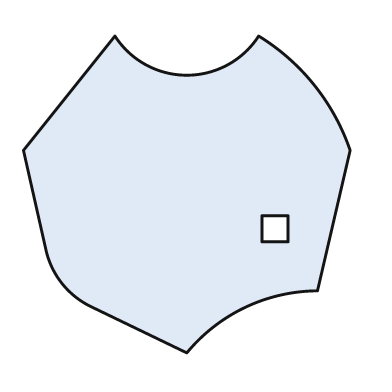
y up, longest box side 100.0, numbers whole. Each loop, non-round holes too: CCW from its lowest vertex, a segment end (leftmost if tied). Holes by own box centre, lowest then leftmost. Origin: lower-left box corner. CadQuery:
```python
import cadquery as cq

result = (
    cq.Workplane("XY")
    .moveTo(50.0, 0.0)
    .threePointArc((68.0, 14.0), (90.0, 19.0))
    .lineTo(100.0, 62.0)
    .threePointArc((89.0, 82.0), (72.0, 97.0))
    .threePointArc((50.0, 85.0), (28.0, 97.0))
    .lineTo(0.0, 62.0)
    .lineTo(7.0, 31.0)
    .threePointArc((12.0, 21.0), (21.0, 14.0))
    .close()
    .moveTo(73.0, 34.0)
    .lineTo(81.0, 34.0)
    .lineTo(81.0, 42.0)
    .lineTo(73.0, 42.0)
    .close()
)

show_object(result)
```